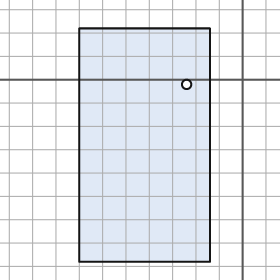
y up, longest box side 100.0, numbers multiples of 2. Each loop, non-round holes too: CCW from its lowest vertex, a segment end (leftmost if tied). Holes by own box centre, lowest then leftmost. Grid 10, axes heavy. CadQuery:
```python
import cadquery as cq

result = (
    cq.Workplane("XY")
    .moveTo(-70.0, -78.0)
    .lineTo(-14.0, -78.0)
    .lineTo(-14.0, 22.0)
    .lineTo(-70.0, 22.0)
    .close()
    .moveTo(-24.0, -2.0)
    .circle(2.0)
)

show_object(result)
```